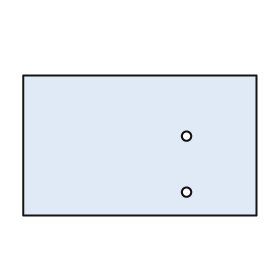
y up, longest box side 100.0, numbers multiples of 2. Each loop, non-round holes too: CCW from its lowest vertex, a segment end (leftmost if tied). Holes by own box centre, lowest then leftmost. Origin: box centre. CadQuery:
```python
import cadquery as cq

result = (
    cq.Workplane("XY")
    .moveTo(-50.0, -30.0)
    .lineTo(50.0, -30.0)
    .lineTo(50.0, 30.0)
    .lineTo(-50.0, 30.0)
    .close()
    .moveTo(20.0, -20.0)
    .circle(2.0)
    .moveTo(20.0, 4.0)
    .circle(2.0)
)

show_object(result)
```